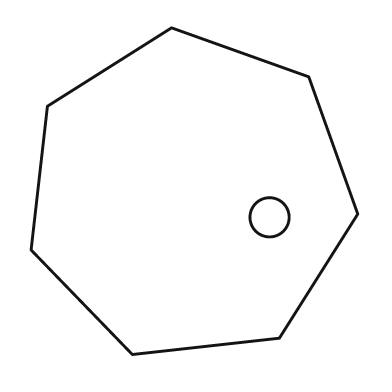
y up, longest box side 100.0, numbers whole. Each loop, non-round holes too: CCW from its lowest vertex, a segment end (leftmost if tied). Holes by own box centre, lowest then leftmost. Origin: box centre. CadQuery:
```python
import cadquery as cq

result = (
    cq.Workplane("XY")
    .moveTo(-19.0, -50.0)
    .lineTo(26.0, -45.0)
    .lineTo(50.0, -7.0)
    .lineTo(35.0, 35.0)
    .lineTo(-7.0, 50.0)
    .lineTo(-45.0, 26.0)
    .lineTo(-50.0, -18.0)
    .close()
    .moveTo(23.0, -8.0)
    .circle(6.0)
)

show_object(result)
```